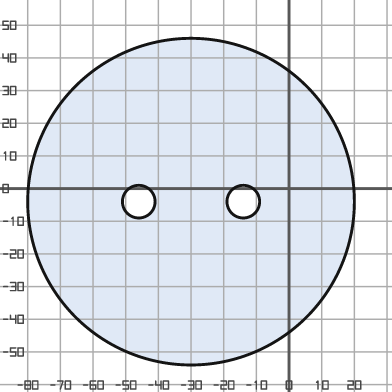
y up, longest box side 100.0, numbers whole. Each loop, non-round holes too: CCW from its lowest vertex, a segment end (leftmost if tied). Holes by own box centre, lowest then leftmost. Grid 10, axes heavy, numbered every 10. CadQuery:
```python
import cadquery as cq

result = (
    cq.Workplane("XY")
    .moveTo(-30.0, -4.0)
    .circle(50.0)
    .moveTo(-46.0, -4.0)
    .circle(5.0)
    .moveTo(-14.0, -4.0)
    .circle(5.0)
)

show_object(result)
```